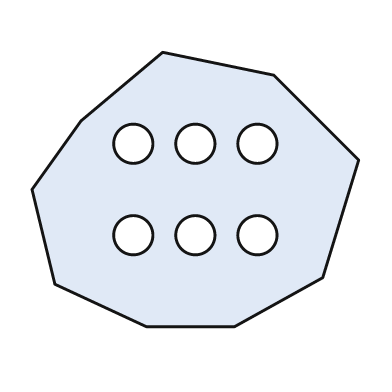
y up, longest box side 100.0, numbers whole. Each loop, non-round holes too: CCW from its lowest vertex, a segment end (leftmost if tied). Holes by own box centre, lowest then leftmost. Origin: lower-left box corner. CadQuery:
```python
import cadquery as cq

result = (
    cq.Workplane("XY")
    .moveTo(35.0, 0.0)
    .lineTo(62.0, 0.0)
    .lineTo(89.0, 15.0)
    .lineTo(100.0, 51.0)
    .lineTo(74.0, 77.0)
    .lineTo(40.0, 84.0)
    .lineTo(15.0, 63.0)
    .lineTo(0.0, 42.0)
    .lineTo(7.0, 13.0)
    .close()
    .moveTo(31.0, 28.0)
    .circle(6.0)
    .moveTo(50.0, 28.0)
    .circle(6.0)
    .moveTo(69.0, 28.0)
    .circle(6.0)
    .moveTo(31.0, 56.0)
    .circle(6.0)
    .moveTo(50.0, 56.0)
    .circle(6.0)
    .moveTo(69.0, 56.0)
    .circle(6.0)
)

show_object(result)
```